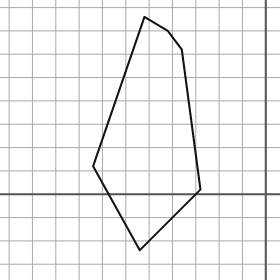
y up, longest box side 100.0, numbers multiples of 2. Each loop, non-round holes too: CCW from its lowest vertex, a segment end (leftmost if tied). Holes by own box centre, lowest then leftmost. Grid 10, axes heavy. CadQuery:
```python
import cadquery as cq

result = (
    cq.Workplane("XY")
    .moveTo(-54.0, -24.0)
    .lineTo(-28.0, 2.0)
    .lineTo(-36.0, 62.0)
    .lineTo(-42.0, 70.0)
    .lineTo(-52.0, 76.0)
    .lineTo(-74.0, 12.0)
    .close()
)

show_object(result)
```